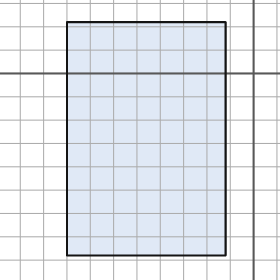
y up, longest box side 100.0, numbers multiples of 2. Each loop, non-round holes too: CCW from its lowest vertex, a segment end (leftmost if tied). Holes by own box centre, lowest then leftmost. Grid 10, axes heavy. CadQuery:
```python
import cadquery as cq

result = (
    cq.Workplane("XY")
    .moveTo(-80.0, -78.0)
    .lineTo(-12.0, -78.0)
    .lineTo(-12.0, 22.0)
    .lineTo(-80.0, 22.0)
    .close()
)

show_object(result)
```